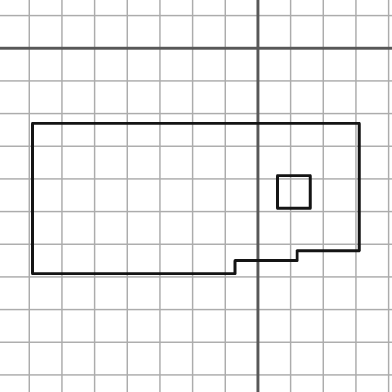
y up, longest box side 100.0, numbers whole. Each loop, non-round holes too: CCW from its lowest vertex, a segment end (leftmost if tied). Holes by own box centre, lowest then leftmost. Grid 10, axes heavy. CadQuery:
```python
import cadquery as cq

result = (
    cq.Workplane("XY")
    .moveTo(-69.0, -69.0)
    .lineTo(-7.0, -69.0)
    .lineTo(-7.0, -65.0)
    .lineTo(12.0, -65.0)
    .lineTo(12.0, -62.0)
    .lineTo(31.0, -62.0)
    .lineTo(31.0, -23.0)
    .lineTo(-69.0, -23.0)
    .close()
    .moveTo(6.0, -49.0)
    .lineTo(16.0, -49.0)
    .lineTo(16.0, -39.0)
    .lineTo(6.0, -39.0)
    .close()
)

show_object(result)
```